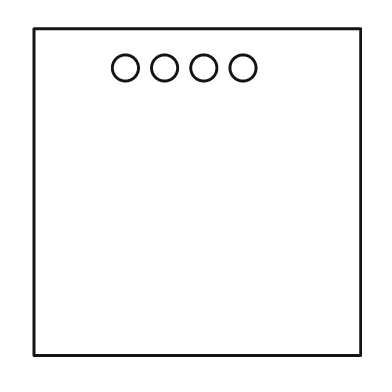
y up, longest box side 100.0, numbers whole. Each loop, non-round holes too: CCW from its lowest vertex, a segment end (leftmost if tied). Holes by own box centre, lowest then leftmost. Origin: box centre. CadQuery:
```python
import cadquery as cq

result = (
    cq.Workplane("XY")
    .moveTo(-50.0, -50.0)
    .lineTo(50.0, -50.0)
    .lineTo(50.0, 50.0)
    .lineTo(-50.0, 50.0)
    .close()
    .moveTo(-22.0, 38.0)
    .circle(4.0)
    .moveTo(-10.0, 38.0)
    .circle(4.0)
    .moveTo(2.0, 38.0)
    .circle(4.0)
    .moveTo(14.0, 38.0)
    .circle(4.0)
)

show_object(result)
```